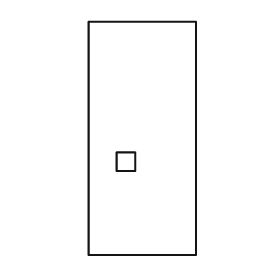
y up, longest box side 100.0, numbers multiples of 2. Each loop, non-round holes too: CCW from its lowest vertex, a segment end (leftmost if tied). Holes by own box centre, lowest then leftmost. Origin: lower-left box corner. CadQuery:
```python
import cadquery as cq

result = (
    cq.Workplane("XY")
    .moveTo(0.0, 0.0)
    .lineTo(46.0, 0.0)
    .lineTo(46.0, 100.0)
    .lineTo(0.0, 100.0)
    .close()
    .moveTo(12.0, 36.0)
    .lineTo(20.0, 36.0)
    .lineTo(20.0, 44.0)
    .lineTo(12.0, 44.0)
    .close()
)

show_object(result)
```